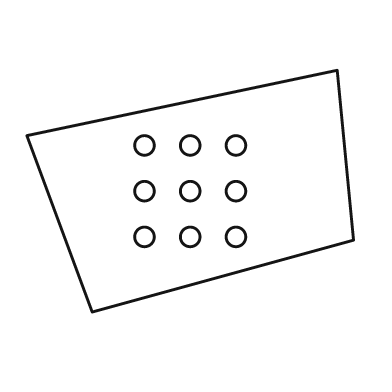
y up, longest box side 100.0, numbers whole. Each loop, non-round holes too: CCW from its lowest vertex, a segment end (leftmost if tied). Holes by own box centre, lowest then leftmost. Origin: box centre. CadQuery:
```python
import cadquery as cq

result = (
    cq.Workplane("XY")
    .moveTo(-30.0, -37.0)
    .lineTo(50.0, -15.0)
    .lineTo(45.0, 37.0)
    .lineTo(-50.0, 17.0)
    .close()
    .moveTo(-14.0, -14.0)
    .circle(3.0)
    .moveTo(0.0, -14.0)
    .circle(3.0)
    .moveTo(14.0, -14.0)
    .circle(3.0)
    .moveTo(-14.0, 0.0)
    .circle(3.0)
    .moveTo(0.0, 0.0)
    .circle(3.0)
    .moveTo(14.0, 0.0)
    .circle(3.0)
    .moveTo(-14.0, 14.0)
    .circle(3.0)
    .moveTo(0.0, 14.0)
    .circle(3.0)
    .moveTo(14.0, 14.0)
    .circle(3.0)
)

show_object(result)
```